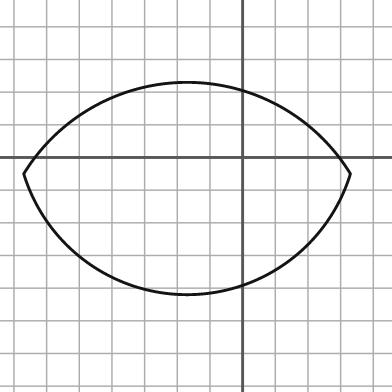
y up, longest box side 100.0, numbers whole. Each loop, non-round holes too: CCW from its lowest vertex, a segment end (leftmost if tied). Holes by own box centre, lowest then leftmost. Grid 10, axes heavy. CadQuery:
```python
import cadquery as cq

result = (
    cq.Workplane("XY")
    .moveTo(-67.0, -5.0)
    .threePointArc((-17.0, -42.0), (33.0, -5.0))
    .threePointArc((-17.0, 23.0), (-67.0, -5.0))
    .close()
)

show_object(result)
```